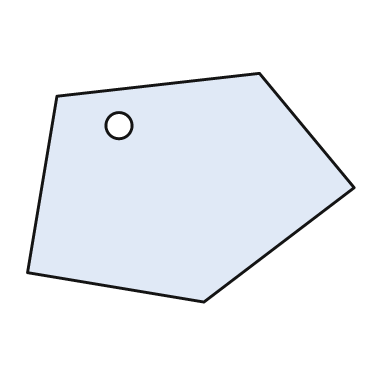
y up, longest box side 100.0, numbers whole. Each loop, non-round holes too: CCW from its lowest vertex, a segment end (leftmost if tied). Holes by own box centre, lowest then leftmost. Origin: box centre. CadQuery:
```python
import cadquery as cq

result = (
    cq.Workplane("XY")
    .moveTo(4.0, -35.0)
    .lineTo(50.0, 0.0)
    .lineTo(21.0, 35.0)
    .lineTo(-41.0, 28.0)
    .lineTo(-50.0, -26.0)
    .close()
    .moveTo(-22.0, 19.0)
    .circle(4.0)
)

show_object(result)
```